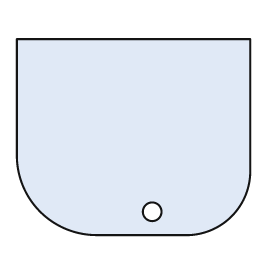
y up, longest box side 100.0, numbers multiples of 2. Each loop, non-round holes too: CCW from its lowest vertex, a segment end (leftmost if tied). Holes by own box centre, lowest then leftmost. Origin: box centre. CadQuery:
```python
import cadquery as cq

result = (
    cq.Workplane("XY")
    .moveTo(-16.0, -42.0)
    .lineTo(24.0, -42.0)
    .threePointArc((42.0, -34.0), (50.0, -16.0))
    .lineTo(50.0, 42.0)
    .lineTo(-50.0, 42.0)
    .lineTo(-50.0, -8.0)
    .threePointArc((-40.0, -32.0), (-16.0, -42.0))
    .close()
    .moveTo(8.0, -32.0)
    .circle(4.0)
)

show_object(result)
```